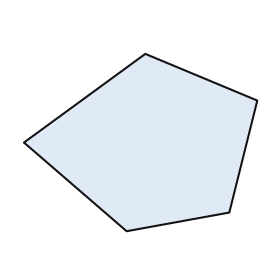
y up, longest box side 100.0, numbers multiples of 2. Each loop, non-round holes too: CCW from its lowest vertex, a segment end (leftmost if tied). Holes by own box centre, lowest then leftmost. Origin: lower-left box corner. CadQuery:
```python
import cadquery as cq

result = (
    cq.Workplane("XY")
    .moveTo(44.0, 0.0)
    .lineTo(88.0, 8.0)
    .lineTo(100.0, 56.0)
    .lineTo(52.0, 76.0)
    .lineTo(0.0, 38.0)
    .close()
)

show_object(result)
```